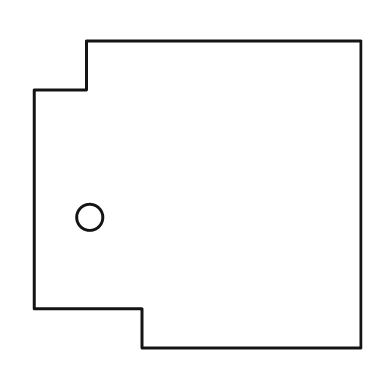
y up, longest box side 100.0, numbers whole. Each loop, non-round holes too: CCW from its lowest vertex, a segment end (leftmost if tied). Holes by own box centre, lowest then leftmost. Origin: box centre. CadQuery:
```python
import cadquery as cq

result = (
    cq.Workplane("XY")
    .moveTo(-17.0, -47.0)
    .lineTo(50.0, -47.0)
    .lineTo(50.0, 47.0)
    .lineTo(-34.0, 47.0)
    .lineTo(-34.0, 32.0)
    .lineTo(-50.0, 32.0)
    .lineTo(-50.0, -35.0)
    .lineTo(-17.0, -35.0)
    .close()
    .moveTo(-33.0, -7.0)
    .circle(4.0)
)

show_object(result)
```